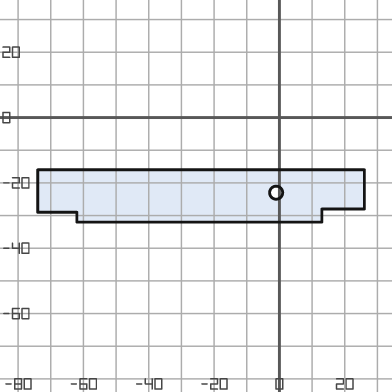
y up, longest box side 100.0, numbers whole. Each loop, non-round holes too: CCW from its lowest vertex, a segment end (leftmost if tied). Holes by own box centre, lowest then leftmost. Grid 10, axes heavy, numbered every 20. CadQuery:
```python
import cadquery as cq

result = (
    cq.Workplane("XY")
    .moveTo(-62.0, -32.0)
    .lineTo(13.0, -32.0)
    .lineTo(13.0, -28.0)
    .lineTo(26.0, -28.0)
    .lineTo(26.0, -16.0)
    .lineTo(-74.0, -16.0)
    .lineTo(-74.0, -29.0)
    .lineTo(-62.0, -29.0)
    .close()
    .moveTo(-1.0, -23.0)
    .circle(2.0)
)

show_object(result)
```